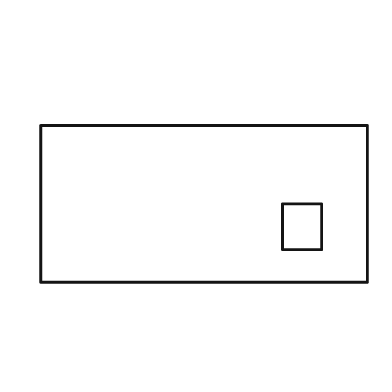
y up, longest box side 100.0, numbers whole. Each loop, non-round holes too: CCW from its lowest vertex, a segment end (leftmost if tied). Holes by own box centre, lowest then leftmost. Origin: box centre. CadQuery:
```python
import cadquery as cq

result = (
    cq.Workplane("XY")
    .moveTo(-50.0, -24.0)
    .lineTo(50.0, -24.0)
    .lineTo(50.0, 24.0)
    .lineTo(-50.0, 24.0)
    .close()
    .moveTo(24.0, -14.0)
    .lineTo(36.0, -14.0)
    .lineTo(36.0, 0.0)
    .lineTo(24.0, 0.0)
    .close()
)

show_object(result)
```